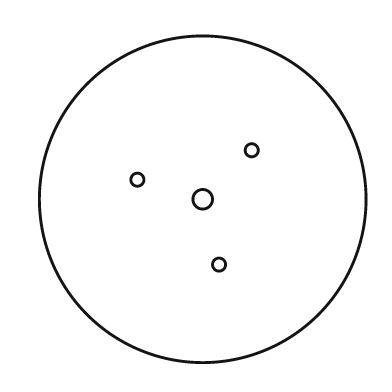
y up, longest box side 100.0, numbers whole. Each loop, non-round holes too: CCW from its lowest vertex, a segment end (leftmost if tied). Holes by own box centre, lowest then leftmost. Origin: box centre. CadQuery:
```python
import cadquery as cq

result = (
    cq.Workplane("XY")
    .moveTo(0.0, 0.0)
    .circle(50.0)
    .moveTo(5.0, -20.0)
    .circle(2.0)
    .moveTo(0.0, 0.0)
    .circle(3.0)
    .moveTo(-20.0, 6.0)
    .circle(2.0)
    .moveTo(15.0, 15.0)
    .circle(2.0)
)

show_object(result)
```